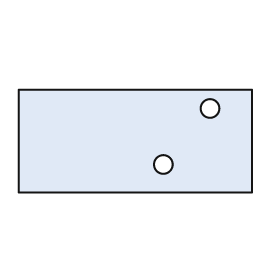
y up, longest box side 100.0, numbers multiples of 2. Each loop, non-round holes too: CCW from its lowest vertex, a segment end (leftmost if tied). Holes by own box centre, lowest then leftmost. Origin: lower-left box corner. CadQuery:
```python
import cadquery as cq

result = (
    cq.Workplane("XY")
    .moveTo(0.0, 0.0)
    .lineTo(100.0, 0.0)
    .lineTo(100.0, 44.0)
    .lineTo(0.0, 44.0)
    .close()
    .moveTo(62.0, 12.0)
    .circle(4.0)
    .moveTo(82.0, 36.0)
    .circle(4.0)
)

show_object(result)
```